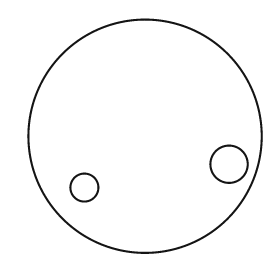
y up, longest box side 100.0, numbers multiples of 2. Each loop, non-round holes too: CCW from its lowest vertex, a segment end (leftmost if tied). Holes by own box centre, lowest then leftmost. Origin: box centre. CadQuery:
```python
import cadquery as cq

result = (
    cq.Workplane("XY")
    .moveTo(0.0, 0.0)
    .circle(50.0)
    .moveTo(-26.0, -22.0)
    .circle(6.0)
    .moveTo(36.0, -12.0)
    .circle(8.0)
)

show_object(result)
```